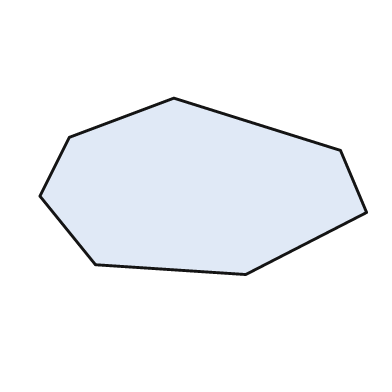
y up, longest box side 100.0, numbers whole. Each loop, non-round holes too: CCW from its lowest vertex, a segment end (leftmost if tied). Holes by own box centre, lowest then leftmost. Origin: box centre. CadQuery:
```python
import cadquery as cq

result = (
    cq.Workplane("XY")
    .moveTo(13.0, -27.0)
    .lineTo(50.0, -8.0)
    .lineTo(42.0, 11.0)
    .lineTo(-9.0, 27.0)
    .lineTo(-41.0, 15.0)
    .lineTo(-50.0, -3.0)
    .lineTo(-33.0, -24.0)
    .close()
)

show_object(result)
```